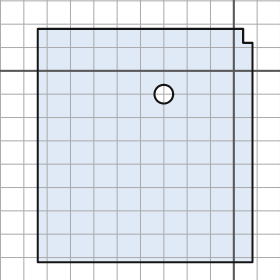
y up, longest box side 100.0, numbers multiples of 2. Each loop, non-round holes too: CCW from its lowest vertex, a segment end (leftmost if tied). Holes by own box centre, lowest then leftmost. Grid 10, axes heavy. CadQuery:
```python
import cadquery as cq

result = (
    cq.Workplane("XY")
    .moveTo(-84.0, -82.0)
    .lineTo(8.0, -82.0)
    .lineTo(8.0, 12.0)
    .lineTo(4.0, 12.0)
    .lineTo(4.0, 18.0)
    .lineTo(-84.0, 18.0)
    .close()
    .moveTo(-30.0, -10.0)
    .circle(4.0)
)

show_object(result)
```